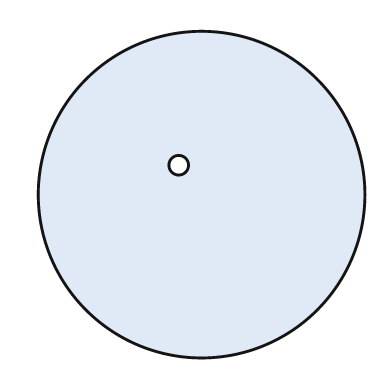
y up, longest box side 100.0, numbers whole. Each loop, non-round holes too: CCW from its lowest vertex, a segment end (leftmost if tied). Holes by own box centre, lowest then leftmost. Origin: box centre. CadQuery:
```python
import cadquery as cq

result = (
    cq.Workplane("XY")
    .moveTo(0.0, 0.0)
    .circle(50.0)
    .moveTo(-7.0, 9.0)
    .circle(3.0)
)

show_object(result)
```